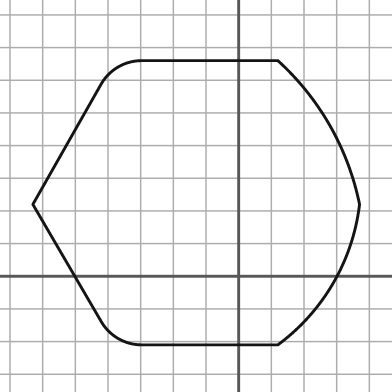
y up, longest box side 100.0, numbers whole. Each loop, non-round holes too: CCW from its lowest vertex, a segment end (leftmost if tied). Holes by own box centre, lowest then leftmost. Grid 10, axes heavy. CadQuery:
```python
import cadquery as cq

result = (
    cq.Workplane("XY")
    .moveTo(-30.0, -21.0)
    .lineTo(12.0, -21.0)
    .threePointArc((29.0, -2.0), (37.0, 22.0))
    .threePointArc((28.0, 46.0), (12.0, 66.0))
    .lineTo(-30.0, 66.0)
    .threePointArc((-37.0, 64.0), (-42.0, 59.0))
    .lineTo(-63.0, 22.0)
    .lineTo(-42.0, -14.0)
    .threePointArc((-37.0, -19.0), (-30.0, -21.0))
    .close()
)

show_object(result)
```